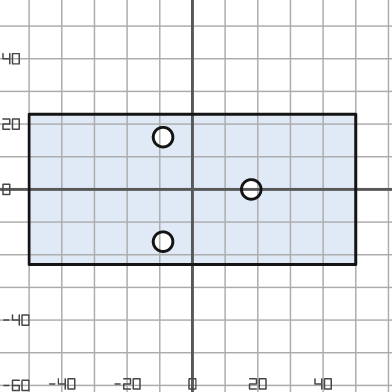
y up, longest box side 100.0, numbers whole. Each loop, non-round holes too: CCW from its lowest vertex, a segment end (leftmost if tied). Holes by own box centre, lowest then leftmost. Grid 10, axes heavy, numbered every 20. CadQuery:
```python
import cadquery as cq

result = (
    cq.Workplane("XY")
    .moveTo(-50.0, -23.0)
    .lineTo(50.0, -23.0)
    .lineTo(50.0, 23.0)
    .lineTo(-50.0, 23.0)
    .close()
    .moveTo(-9.0, -16.0)
    .circle(3.0)
    .moveTo(18.0, 0.0)
    .circle(3.0)
    .moveTo(-9.0, 16.0)
    .circle(3.0)
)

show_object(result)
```